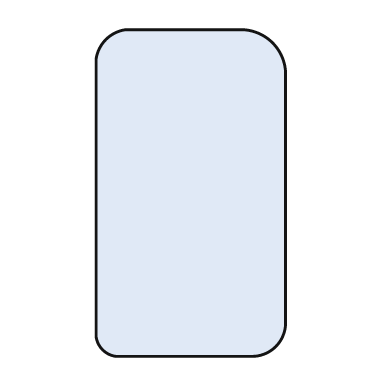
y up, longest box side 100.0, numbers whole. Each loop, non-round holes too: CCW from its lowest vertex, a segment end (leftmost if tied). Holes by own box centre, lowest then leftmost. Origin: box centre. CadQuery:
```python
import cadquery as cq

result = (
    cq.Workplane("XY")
    .moveTo(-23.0, -50.0)
    .lineTo(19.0, -50.0)
    .threePointArc((26.0, -47.0), (29.0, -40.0))
    .lineTo(29.0, 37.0)
    .threePointArc((25.0, 46.0), (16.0, 50.0))
    .lineTo(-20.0, 50.0)
    .threePointArc((-26.0, 47.0), (-29.0, 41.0))
    .lineTo(-29.0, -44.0)
    .threePointArc((-27.0, -48.0), (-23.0, -50.0))
    .close()
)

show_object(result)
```